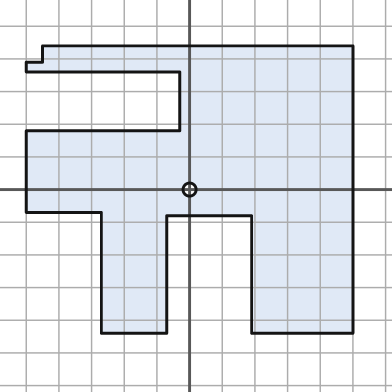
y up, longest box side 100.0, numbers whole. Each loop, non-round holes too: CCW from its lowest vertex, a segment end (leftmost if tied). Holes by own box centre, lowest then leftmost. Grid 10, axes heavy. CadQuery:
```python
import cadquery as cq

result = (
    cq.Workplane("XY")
    .moveTo(-27.0, -44.0)
    .lineTo(-7.0, -44.0)
    .lineTo(-7.0, -8.0)
    .lineTo(19.0, -8.0)
    .lineTo(19.0, -44.0)
    .lineTo(50.0, -44.0)
    .lineTo(50.0, 44.0)
    .lineTo(-45.0, 44.0)
    .lineTo(-45.0, 39.0)
    .lineTo(-50.0, 39.0)
    .lineTo(-50.0, 36.0)
    .lineTo(-3.0, 36.0)
    .lineTo(-3.0, 18.0)
    .lineTo(-50.0, 18.0)
    .lineTo(-50.0, -7.0)
    .lineTo(-27.0, -7.0)
    .close()
    .moveTo(0.0, 0.0)
    .circle(2.0)
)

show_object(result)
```